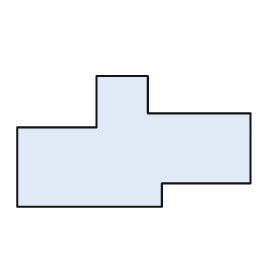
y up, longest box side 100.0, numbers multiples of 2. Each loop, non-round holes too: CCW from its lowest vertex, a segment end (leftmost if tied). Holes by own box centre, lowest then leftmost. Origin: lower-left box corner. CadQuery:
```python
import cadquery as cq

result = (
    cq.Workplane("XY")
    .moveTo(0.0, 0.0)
    .lineTo(62.0, 0.0)
    .lineTo(62.0, 10.0)
    .lineTo(100.0, 10.0)
    .lineTo(100.0, 40.0)
    .lineTo(56.0, 40.0)
    .lineTo(56.0, 56.0)
    .lineTo(34.0, 56.0)
    .lineTo(34.0, 34.0)
    .lineTo(0.0, 34.0)
    .close()
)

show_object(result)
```